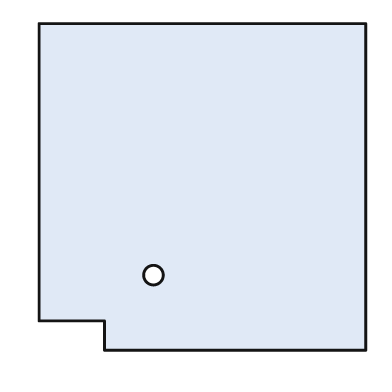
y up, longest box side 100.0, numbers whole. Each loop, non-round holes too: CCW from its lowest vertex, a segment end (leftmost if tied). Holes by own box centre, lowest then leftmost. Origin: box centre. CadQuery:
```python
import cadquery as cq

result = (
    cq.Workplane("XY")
    .moveTo(-30.0, -50.0)
    .lineTo(50.0, -50.0)
    .lineTo(50.0, 50.0)
    .lineTo(-50.0, 50.0)
    .lineTo(-50.0, -41.0)
    .lineTo(-30.0, -41.0)
    .close()
    .moveTo(-15.0, -27.0)
    .circle(3.0)
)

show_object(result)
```